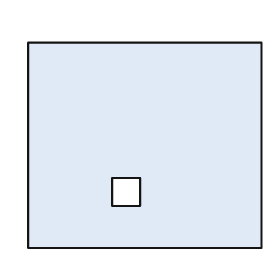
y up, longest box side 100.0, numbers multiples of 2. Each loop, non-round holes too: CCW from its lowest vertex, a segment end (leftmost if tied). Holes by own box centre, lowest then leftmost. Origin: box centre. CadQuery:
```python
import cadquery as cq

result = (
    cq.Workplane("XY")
    .moveTo(-50.0, -44.0)
    .lineTo(50.0, -44.0)
    .lineTo(50.0, 44.0)
    .lineTo(-50.0, 44.0)
    .close()
    .moveTo(-14.0, -26.0)
    .lineTo(-2.0, -26.0)
    .lineTo(-2.0, -14.0)
    .lineTo(-14.0, -14.0)
    .close()
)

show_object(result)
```